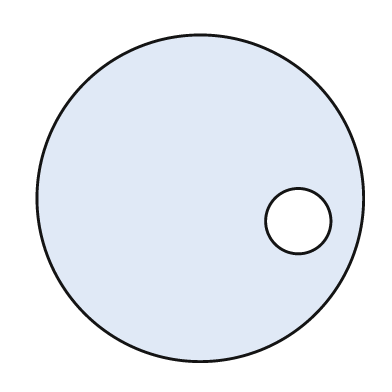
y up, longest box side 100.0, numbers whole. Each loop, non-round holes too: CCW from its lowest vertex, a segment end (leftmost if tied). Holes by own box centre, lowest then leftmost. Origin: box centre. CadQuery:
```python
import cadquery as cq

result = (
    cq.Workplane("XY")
    .moveTo(0.0, 0.0)
    .circle(50.0)
    .moveTo(30.0, -7.0)
    .circle(10.0)
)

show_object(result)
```